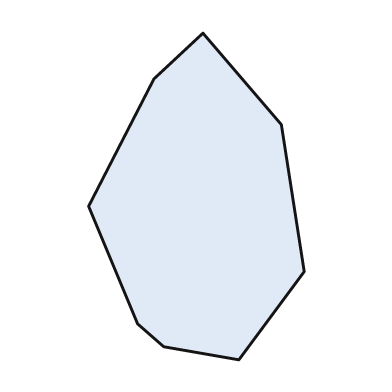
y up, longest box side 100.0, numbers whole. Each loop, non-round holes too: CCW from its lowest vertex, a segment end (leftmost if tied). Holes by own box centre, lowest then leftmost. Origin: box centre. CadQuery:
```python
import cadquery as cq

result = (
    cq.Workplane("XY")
    .moveTo(13.0, -50.0)
    .lineTo(33.0, -23.0)
    .lineTo(26.0, 22.0)
    .lineTo(2.0, 50.0)
    .lineTo(-13.0, 36.0)
    .lineTo(-33.0, -3.0)
    .lineTo(-18.0, -39.0)
    .lineTo(-10.0, -46.0)
    .close()
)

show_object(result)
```